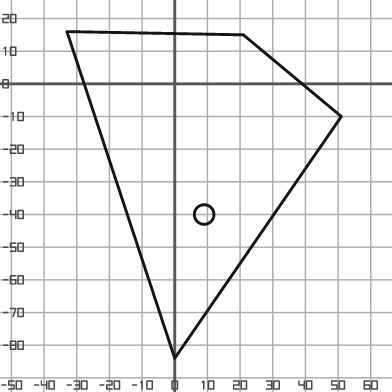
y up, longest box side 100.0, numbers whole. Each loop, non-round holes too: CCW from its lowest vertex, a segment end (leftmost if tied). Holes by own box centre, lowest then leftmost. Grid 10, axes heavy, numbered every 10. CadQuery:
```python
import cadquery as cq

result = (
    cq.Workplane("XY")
    .moveTo(0.0, -84.0)
    .lineTo(51.0, -10.0)
    .lineTo(21.0, 15.0)
    .lineTo(-33.0, 16.0)
    .close()
    .moveTo(9.0, -40.0)
    .circle(3.0)
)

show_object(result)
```